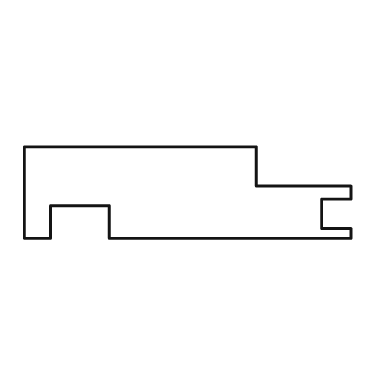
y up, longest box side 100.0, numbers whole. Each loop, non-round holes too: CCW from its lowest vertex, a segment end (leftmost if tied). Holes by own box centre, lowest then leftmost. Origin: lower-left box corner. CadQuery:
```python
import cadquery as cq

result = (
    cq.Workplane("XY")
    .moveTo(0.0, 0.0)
    .lineTo(8.0, 0.0)
    .lineTo(8.0, 10.0)
    .lineTo(26.0, 10.0)
    .lineTo(26.0, 0.0)
    .lineTo(100.0, 0.0)
    .lineTo(100.0, 3.0)
    .lineTo(91.0, 3.0)
    .lineTo(91.0, 12.0)
    .lineTo(100.0, 12.0)
    .lineTo(100.0, 16.0)
    .lineTo(71.0, 16.0)
    .lineTo(71.0, 28.0)
    .lineTo(0.0, 28.0)
    .close()
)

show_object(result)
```